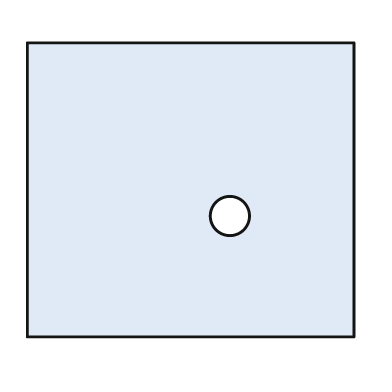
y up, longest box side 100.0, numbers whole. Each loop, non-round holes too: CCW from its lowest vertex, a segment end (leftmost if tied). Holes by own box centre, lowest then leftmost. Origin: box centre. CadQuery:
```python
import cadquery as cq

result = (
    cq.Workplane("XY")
    .moveTo(-50.0, -45.0)
    .lineTo(50.0, -45.0)
    .lineTo(50.0, 45.0)
    .lineTo(-50.0, 45.0)
    .close()
    .moveTo(12.0, -8.0)
    .circle(6.0)
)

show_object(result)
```